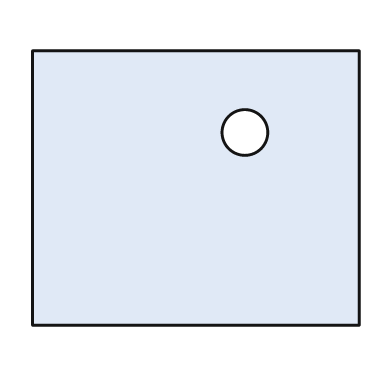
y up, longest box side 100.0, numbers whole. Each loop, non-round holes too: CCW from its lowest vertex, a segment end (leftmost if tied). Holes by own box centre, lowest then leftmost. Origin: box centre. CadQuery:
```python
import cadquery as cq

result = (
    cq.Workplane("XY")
    .moveTo(-50.0, -42.0)
    .lineTo(50.0, -42.0)
    .lineTo(50.0, 42.0)
    .lineTo(-50.0, 42.0)
    .close()
    .moveTo(15.0, 17.0)
    .circle(7.0)
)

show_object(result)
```